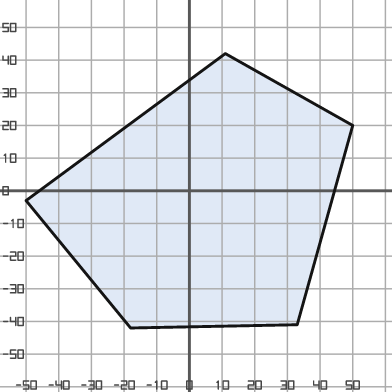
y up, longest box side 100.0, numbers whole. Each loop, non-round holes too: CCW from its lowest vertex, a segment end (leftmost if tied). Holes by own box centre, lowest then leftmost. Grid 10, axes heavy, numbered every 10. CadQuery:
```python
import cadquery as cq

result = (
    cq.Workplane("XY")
    .moveTo(-18.0, -42.0)
    .lineTo(33.0, -41.0)
    .lineTo(50.0, 20.0)
    .lineTo(11.0, 42.0)
    .lineTo(-50.0, -3.0)
    .close()
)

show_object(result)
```